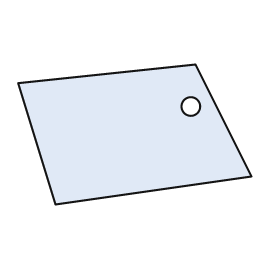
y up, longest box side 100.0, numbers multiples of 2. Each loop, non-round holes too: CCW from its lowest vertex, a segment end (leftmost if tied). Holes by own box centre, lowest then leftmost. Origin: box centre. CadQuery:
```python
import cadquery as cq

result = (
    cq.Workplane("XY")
    .moveTo(-34.0, -30.0)
    .lineTo(50.0, -18.0)
    .lineTo(26.0, 30.0)
    .lineTo(-50.0, 22.0)
    .close()
    .moveTo(24.0, 12.0)
    .circle(4.0)
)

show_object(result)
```